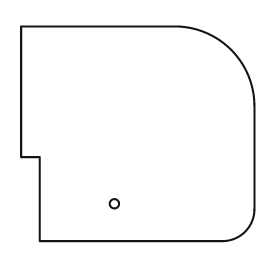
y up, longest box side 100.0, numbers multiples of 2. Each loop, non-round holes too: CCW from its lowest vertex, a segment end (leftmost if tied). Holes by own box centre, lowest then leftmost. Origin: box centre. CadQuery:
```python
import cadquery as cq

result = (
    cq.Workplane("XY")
    .moveTo(-42.0, -46.0)
    .lineTo(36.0, -46.0)
    .threePointArc((46.0, -42.0), (50.0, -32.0))
    .lineTo(50.0, 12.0)
    .threePointArc((40.0, 36.0), (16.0, 46.0))
    .lineTo(-50.0, 46.0)
    .lineTo(-50.0, -10.0)
    .lineTo(-42.0, -10.0)
    .close()
    .moveTo(-10.0, -30.0)
    .circle(2.0)
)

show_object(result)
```